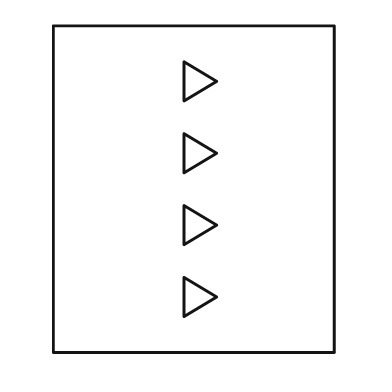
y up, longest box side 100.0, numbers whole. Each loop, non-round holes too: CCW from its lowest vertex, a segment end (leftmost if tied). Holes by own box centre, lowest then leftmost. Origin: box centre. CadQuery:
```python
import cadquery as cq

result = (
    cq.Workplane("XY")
    .moveTo(-43.0, -50.0)
    .lineTo(43.0, -50.0)
    .lineTo(43.0, 50.0)
    .lineTo(-43.0, 50.0)
    .close()
    .moveTo(-3.0, -39.0)
    .lineTo(7.0, -33.0)
    .lineTo(-3.0, -27.0)
    .close()
    .moveTo(-3.0, -17.0)
    .lineTo(7.0, -11.0)
    .lineTo(-3.0, -5.0)
    .close()
    .moveTo(-3.0, 5.0)
    .lineTo(7.0, 11.0)
    .lineTo(-3.0, 17.0)
    .close()
    .moveTo(-3.0, 27.0)
    .lineTo(7.0, 33.0)
    .lineTo(-3.0, 39.0)
    .close()
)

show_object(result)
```